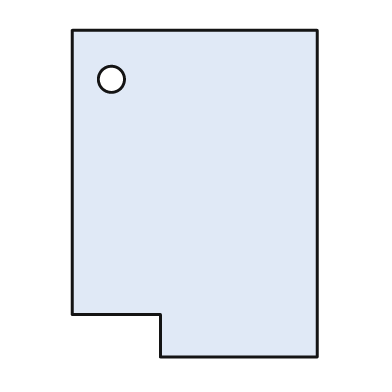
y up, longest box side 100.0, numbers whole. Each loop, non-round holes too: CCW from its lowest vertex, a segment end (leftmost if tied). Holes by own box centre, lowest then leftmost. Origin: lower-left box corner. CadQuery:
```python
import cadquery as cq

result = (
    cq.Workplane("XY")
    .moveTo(27.0, 0.0)
    .lineTo(75.0, 0.0)
    .lineTo(75.0, 100.0)
    .lineTo(0.0, 100.0)
    .lineTo(0.0, 13.0)
    .lineTo(27.0, 13.0)
    .close()
    .moveTo(12.0, 85.0)
    .circle(4.0)
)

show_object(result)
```